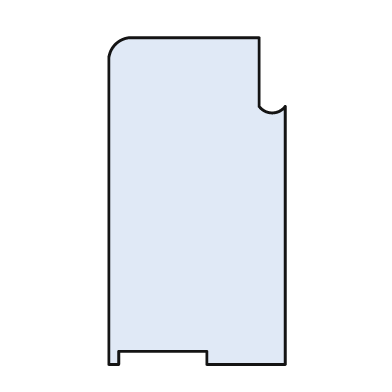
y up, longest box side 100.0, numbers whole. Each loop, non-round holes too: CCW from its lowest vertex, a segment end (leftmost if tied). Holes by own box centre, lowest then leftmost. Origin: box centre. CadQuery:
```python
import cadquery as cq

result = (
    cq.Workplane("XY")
    .moveTo(-27.0, -50.0)
    .lineTo(-24.0, -50.0)
    .lineTo(-24.0, -46.0)
    .lineTo(3.0, -46.0)
    .lineTo(3.0, -50.0)
    .lineTo(27.0, -50.0)
    .lineTo(27.0, 29.0)
    .threePointArc((23.0, 27.0), (19.0, 29.0))
    .lineTo(19.0, 50.0)
    .lineTo(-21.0, 50.0)
    .threePointArc((-25.0, 48.0), (-27.0, 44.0))
    .close()
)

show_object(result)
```